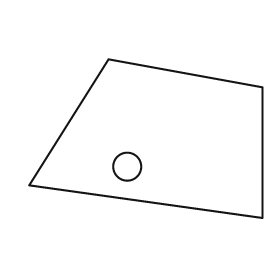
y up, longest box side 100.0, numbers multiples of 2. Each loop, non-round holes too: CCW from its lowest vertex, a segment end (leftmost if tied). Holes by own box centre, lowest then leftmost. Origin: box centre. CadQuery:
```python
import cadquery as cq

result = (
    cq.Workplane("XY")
    .moveTo(50.0, -34.0)
    .lineTo(50.0, 22.0)
    .lineTo(-16.0, 34.0)
    .lineTo(-50.0, -20.0)
    .close()
    .moveTo(-8.0, -12.0)
    .circle(6.0)
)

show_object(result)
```